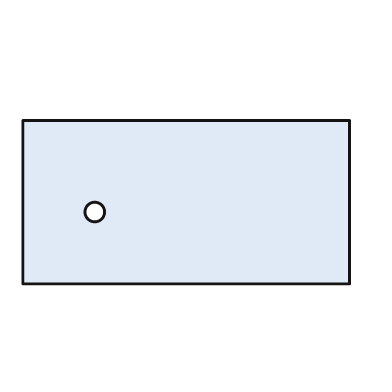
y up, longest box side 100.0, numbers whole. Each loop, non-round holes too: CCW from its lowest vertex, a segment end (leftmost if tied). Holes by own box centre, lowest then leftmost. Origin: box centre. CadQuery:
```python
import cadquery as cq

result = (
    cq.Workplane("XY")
    .moveTo(-50.0, -25.0)
    .lineTo(50.0, -25.0)
    .lineTo(50.0, 25.0)
    .lineTo(-50.0, 25.0)
    .close()
    .moveTo(-28.0, -3.0)
    .circle(3.0)
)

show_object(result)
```